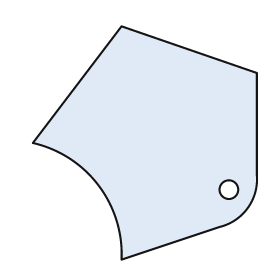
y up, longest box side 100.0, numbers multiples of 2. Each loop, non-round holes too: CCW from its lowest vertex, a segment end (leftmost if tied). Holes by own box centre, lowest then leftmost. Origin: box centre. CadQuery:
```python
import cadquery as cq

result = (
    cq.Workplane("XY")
    .moveTo(-10.0, -50.0)
    .lineTo(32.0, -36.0)
    .threePointArc((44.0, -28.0), (48.0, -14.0))
    .lineTo(48.0, 30.0)
    .lineTo(-10.0, 50.0)
    .lineTo(-48.0, 0.0)
    .threePointArc((-20.0, -18.0), (-10.0, -50.0))
    .close()
    .moveTo(36.0, -20.0)
    .circle(4.0)
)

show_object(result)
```